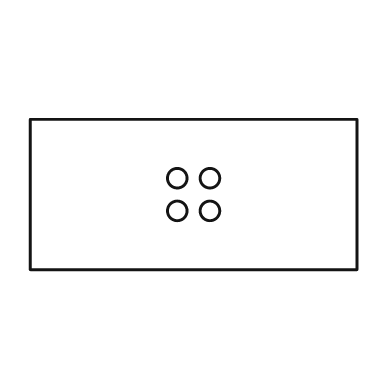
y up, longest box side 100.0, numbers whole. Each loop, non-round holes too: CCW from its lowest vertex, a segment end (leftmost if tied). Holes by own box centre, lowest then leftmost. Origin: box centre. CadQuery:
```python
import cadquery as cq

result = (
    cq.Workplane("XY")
    .moveTo(-50.0, -23.0)
    .lineTo(50.0, -23.0)
    .lineTo(50.0, 23.0)
    .lineTo(-50.0, 23.0)
    .close()
    .moveTo(-5.0, -5.0)
    .circle(3.0)
    .moveTo(5.0, -5.0)
    .circle(3.0)
    .moveTo(-5.0, 5.0)
    .circle(3.0)
    .moveTo(5.0, 5.0)
    .circle(3.0)
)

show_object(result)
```